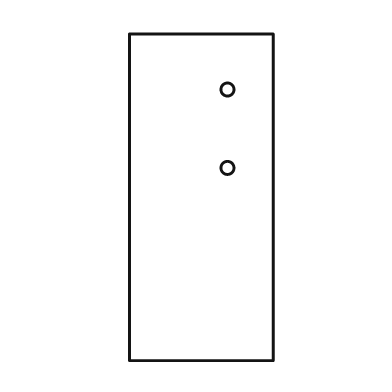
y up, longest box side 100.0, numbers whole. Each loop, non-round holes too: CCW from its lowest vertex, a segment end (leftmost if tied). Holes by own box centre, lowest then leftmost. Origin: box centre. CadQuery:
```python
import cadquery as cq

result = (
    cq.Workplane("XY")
    .moveTo(-22.0, -50.0)
    .lineTo(22.0, -50.0)
    .lineTo(22.0, 50.0)
    .lineTo(-22.0, 50.0)
    .close()
    .moveTo(8.0, 9.0)
    .circle(2.0)
    .moveTo(8.0, 33.0)
    .circle(2.0)
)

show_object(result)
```